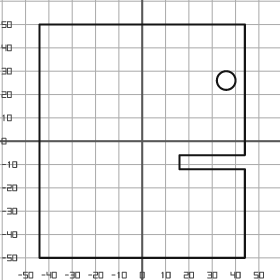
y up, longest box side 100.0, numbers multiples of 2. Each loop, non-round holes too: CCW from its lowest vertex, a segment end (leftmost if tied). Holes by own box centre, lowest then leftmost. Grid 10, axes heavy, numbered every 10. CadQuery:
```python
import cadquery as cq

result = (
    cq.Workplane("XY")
    .moveTo(-44.0, -50.0)
    .lineTo(44.0, -50.0)
    .lineTo(44.0, -12.0)
    .lineTo(16.0, -12.0)
    .lineTo(16.0, -6.0)
    .lineTo(44.0, -6.0)
    .lineTo(44.0, 50.0)
    .lineTo(-44.0, 50.0)
    .close()
    .moveTo(36.0, 26.0)
    .circle(4.0)
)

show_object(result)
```